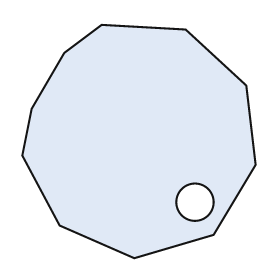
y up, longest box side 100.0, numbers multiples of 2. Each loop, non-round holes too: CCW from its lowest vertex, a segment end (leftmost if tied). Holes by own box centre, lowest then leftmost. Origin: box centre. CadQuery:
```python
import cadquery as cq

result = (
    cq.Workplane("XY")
    .moveTo(-2.0, -50.0)
    .lineTo(32.0, -40.0)
    .lineTo(50.0, -10.0)
    .lineTo(46.0, 24.0)
    .lineTo(20.0, 48.0)
    .lineTo(-16.0, 50.0)
    .lineTo(-32.0, 38.0)
    .lineTo(-46.0, 14.0)
    .lineTo(-50.0, -6.0)
    .lineTo(-34.0, -36.0)
    .close()
    .moveTo(24.0, -26.0)
    .circle(8.0)
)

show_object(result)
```